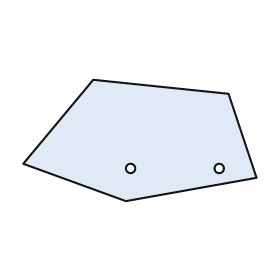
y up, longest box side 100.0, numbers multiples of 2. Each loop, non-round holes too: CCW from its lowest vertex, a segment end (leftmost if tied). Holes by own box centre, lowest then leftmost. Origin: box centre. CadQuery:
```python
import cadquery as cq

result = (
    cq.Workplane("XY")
    .moveTo(-6.0, -26.0)
    .lineTo(50.0, -16.0)
    .lineTo(38.0, 20.0)
    .lineTo(-20.0, 26.0)
    .lineTo(-50.0, -10.0)
    .close()
    .moveTo(-4.0, -12.0)
    .circle(2.0)
    .moveTo(34.0, -12.0)
    .circle(2.0)
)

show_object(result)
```